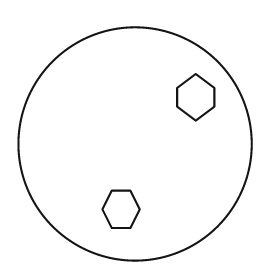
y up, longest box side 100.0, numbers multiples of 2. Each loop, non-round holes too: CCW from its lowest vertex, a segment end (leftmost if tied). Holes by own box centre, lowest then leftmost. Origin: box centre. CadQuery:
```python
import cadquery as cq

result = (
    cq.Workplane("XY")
    .moveTo(0.0, 0.0)
    .circle(50.0)
    .moveTo(-10.0, -36.0)
    .lineTo(-2.0, -36.0)
    .lineTo(2.0, -28.0)
    .lineTo(-2.0, -20.0)
    .lineTo(-10.0, -20.0)
    .lineTo(-14.0, -28.0)
    .close()
    .moveTo(26.0, 10.0)
    .lineTo(34.0, 16.0)
    .lineTo(34.0, 24.0)
    .lineTo(26.0, 30.0)
    .lineTo(18.0, 24.0)
    .lineTo(18.0, 16.0)
    .close()
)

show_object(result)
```